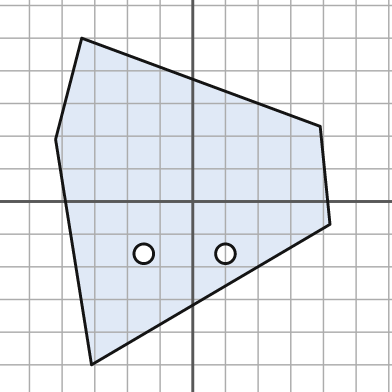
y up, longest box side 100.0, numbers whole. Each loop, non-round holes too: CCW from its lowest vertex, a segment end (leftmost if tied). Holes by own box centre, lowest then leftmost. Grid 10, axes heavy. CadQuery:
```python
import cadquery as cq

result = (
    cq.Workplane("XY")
    .moveTo(-31.0, -50.0)
    .lineTo(42.0, -7.0)
    .lineTo(39.0, 23.0)
    .lineTo(-34.0, 50.0)
    .lineTo(-42.0, 19.0)
    .close()
    .moveTo(-15.0, -16.0)
    .circle(3.0)
    .moveTo(10.0, -16.0)
    .circle(3.0)
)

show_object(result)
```